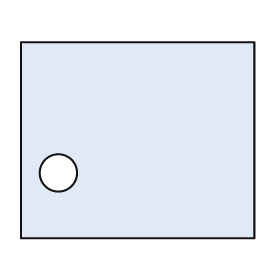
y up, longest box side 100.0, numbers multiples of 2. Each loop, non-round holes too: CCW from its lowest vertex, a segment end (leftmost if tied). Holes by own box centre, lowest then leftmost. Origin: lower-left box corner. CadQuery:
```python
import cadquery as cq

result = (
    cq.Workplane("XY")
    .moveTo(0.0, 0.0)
    .lineTo(100.0, 0.0)
    .lineTo(100.0, 84.0)
    .lineTo(0.0, 84.0)
    .close()
    .moveTo(16.0, 28.0)
    .circle(8.0)
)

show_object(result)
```